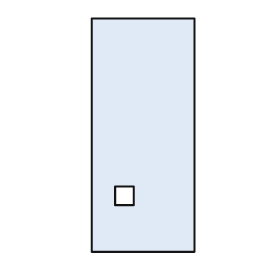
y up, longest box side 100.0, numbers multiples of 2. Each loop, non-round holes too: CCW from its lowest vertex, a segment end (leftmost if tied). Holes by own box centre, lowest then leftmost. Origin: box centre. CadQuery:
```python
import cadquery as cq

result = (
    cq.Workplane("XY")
    .moveTo(-22.0, -50.0)
    .lineTo(22.0, -50.0)
    .lineTo(22.0, 50.0)
    .lineTo(-22.0, 50.0)
    .close()
    .moveTo(-12.0, -30.0)
    .lineTo(-4.0, -30.0)
    .lineTo(-4.0, -22.0)
    .lineTo(-12.0, -22.0)
    .close()
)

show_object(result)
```